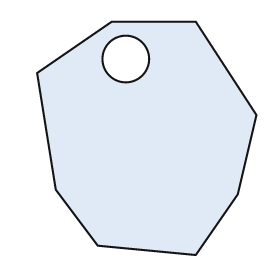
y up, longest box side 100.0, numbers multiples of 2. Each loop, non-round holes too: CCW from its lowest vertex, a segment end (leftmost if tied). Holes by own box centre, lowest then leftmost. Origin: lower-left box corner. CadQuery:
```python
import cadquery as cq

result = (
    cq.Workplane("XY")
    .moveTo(68.0, 0.0)
    .lineTo(86.0, 26.0)
    .lineTo(94.0, 60.0)
    .lineTo(68.0, 100.0)
    .lineTo(32.0, 100.0)
    .lineTo(0.0, 78.0)
    .lineTo(8.0, 28.0)
    .lineTo(26.0, 4.0)
    .close()
    .moveTo(38.0, 84.0)
    .circle(10.0)
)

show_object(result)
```